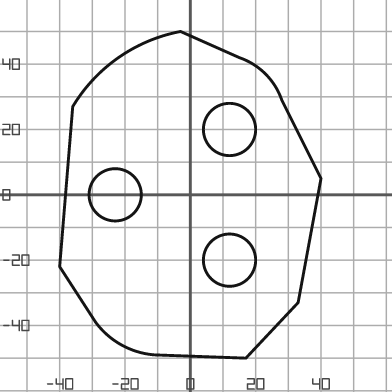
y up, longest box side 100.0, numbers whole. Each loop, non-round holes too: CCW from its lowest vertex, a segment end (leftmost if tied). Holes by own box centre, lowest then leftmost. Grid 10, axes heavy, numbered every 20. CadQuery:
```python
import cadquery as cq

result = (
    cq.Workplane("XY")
    .moveTo(17.0, -50.0)
    .lineTo(33.0, -33.0)
    .lineTo(40.0, 5.0)
    .lineTo(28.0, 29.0)
    .threePointArc((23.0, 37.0), (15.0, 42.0))
    .lineTo(-3.0, 50.0)
    .threePointArc((-22.0, 42.0), (-36.0, 27.0))
    .lineTo(-40.0, -22.0)
    .lineTo(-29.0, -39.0)
    .threePointArc((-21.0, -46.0), (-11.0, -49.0))
    .close()
    .moveTo(12.0, -20.0)
    .circle(8.0)
    .moveTo(-23.0, 0.0)
    .circle(8.0)
    .moveTo(12.0, 20.0)
    .circle(8.0)
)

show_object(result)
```